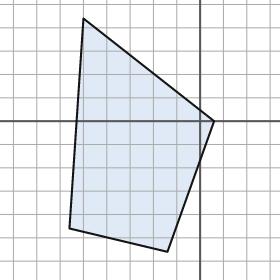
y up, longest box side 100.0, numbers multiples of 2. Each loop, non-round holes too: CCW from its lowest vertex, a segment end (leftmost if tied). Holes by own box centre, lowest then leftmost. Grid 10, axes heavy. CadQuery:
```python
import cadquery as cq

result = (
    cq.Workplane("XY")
    .moveTo(-14.0, -56.0)
    .lineTo(6.0, 0.0)
    .lineTo(-50.0, 44.0)
    .lineTo(-56.0, -46.0)
    .close()
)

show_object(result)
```